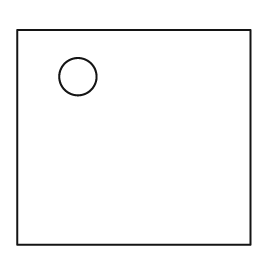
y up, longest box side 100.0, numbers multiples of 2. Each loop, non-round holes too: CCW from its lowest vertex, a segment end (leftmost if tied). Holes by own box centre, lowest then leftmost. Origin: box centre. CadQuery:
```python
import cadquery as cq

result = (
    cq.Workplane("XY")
    .moveTo(-50.0, -46.0)
    .lineTo(50.0, -46.0)
    .lineTo(50.0, 46.0)
    .lineTo(-50.0, 46.0)
    .close()
    .moveTo(-24.0, 26.0)
    .circle(8.0)
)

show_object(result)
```